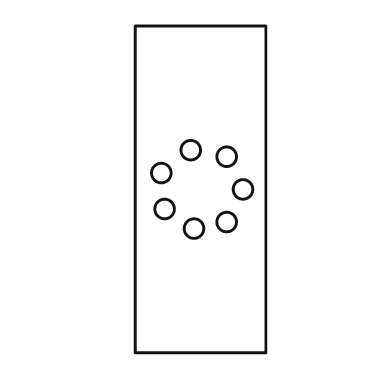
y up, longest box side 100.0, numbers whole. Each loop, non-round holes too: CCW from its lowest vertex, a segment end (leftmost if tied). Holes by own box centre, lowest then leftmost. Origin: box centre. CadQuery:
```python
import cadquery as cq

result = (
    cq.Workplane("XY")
    .moveTo(-20.0, -50.0)
    .lineTo(20.0, -50.0)
    .lineTo(20.0, 50.0)
    .lineTo(-20.0, 50.0)
    .close()
    .moveTo(-2.0, -12.0)
    .circle(3.0)
    .moveTo(8.0, -10.0)
    .circle(3.0)
    .moveTo(-11.0, -6.0)
    .circle(3.0)
    .moveTo(13.0, 0.0)
    .circle(3.0)
    .moveTo(-12.0, 5.0)
    .circle(3.0)
    .moveTo(8.0, 10.0)
    .circle(3.0)
    .moveTo(-3.0, 12.0)
    .circle(3.0)
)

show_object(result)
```